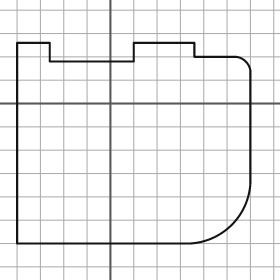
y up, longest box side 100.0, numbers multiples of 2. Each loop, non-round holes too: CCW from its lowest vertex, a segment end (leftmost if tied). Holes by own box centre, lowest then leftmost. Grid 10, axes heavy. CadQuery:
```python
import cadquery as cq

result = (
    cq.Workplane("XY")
    .moveTo(-40.0, -60.0)
    .lineTo(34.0, -60.0)
    .threePointArc((52.0, -52.0), (60.0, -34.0))
    .lineTo(60.0, 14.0)
    .threePointArc((58.0, 18.0), (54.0, 20.0))
    .lineTo(36.0, 20.0)
    .lineTo(36.0, 26.0)
    .lineTo(10.0, 26.0)
    .lineTo(10.0, 18.0)
    .lineTo(-26.0, 18.0)
    .lineTo(-26.0, 26.0)
    .lineTo(-40.0, 26.0)
    .close()
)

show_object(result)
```